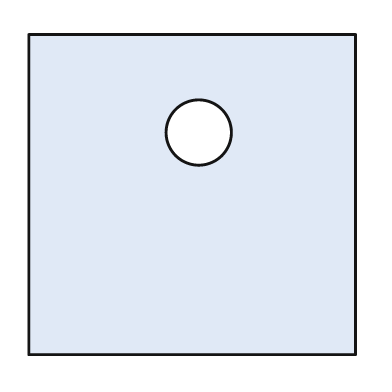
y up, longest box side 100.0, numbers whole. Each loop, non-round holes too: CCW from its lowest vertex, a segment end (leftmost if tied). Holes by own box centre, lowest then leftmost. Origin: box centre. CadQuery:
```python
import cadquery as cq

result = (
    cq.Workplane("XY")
    .moveTo(-50.0, -49.0)
    .lineTo(50.0, -49.0)
    .lineTo(50.0, 49.0)
    .lineTo(-50.0, 49.0)
    .close()
    .moveTo(2.0, 19.0)
    .circle(10.0)
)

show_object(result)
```